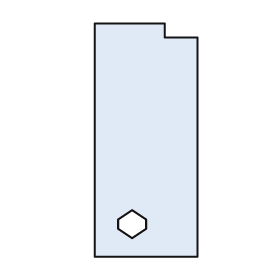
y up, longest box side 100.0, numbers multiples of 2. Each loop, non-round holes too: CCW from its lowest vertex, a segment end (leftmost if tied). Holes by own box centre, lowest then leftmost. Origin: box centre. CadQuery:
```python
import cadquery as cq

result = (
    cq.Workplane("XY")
    .moveTo(-22.0, -50.0)
    .lineTo(22.0, -50.0)
    .lineTo(22.0, 44.0)
    .lineTo(8.0, 44.0)
    .lineTo(8.0, 50.0)
    .lineTo(-22.0, 50.0)
    .close()
    .moveTo(-6.0, -42.0)
    .lineTo(0.0, -38.0)
    .lineTo(0.0, -34.0)
    .lineTo(-6.0, -30.0)
    .lineTo(-12.0, -34.0)
    .lineTo(-12.0, -38.0)
    .close()
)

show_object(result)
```